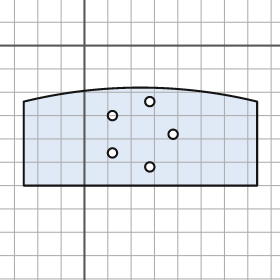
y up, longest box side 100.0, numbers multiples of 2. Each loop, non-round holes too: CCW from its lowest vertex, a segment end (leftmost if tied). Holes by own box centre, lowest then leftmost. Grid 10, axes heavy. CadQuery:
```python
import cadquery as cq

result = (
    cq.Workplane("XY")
    .moveTo(-26.0, -60.0)
    .lineTo(74.0, -60.0)
    .lineTo(74.0, -24.0)
    .threePointArc((24.0, -18.0), (-26.0, -24.0))
    .close()
    .moveTo(28.0, -52.0)
    .circle(2.0)
    .moveTo(12.0, -46.0)
    .circle(2.0)
    .moveTo(38.0, -38.0)
    .circle(2.0)
    .moveTo(12.0, -30.0)
    .circle(2.0)
    .moveTo(28.0, -24.0)
    .circle(2.0)
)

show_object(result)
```